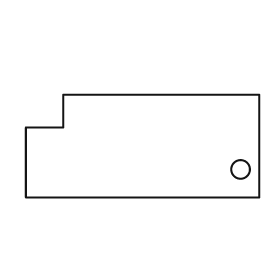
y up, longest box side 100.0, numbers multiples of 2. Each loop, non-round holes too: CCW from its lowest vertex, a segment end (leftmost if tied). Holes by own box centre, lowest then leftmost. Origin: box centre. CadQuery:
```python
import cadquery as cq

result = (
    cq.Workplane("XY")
    .moveTo(-50.0, -22.0)
    .lineTo(50.0, -22.0)
    .lineTo(50.0, 22.0)
    .lineTo(-34.0, 22.0)
    .lineTo(-34.0, 8.0)
    .lineTo(-50.0, 8.0)
    .close()
    .moveTo(42.0, -10.0)
    .circle(4.0)
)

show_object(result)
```